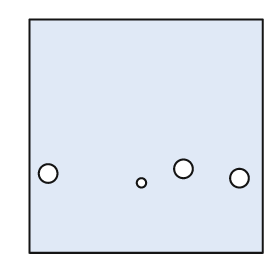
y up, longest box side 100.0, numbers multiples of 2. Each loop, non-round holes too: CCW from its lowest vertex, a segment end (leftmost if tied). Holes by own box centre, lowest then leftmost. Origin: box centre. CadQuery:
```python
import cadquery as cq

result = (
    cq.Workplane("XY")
    .moveTo(-50.0, -50.0)
    .lineTo(50.0, -50.0)
    .lineTo(50.0, 50.0)
    .lineTo(-50.0, 50.0)
    .close()
    .moveTo(-2.0, -20.0)
    .circle(2.0)
    .moveTo(40.0, -18.0)
    .circle(4.0)
    .moveTo(-42.0, -16.0)
    .circle(4.0)
    .moveTo(16.0, -14.0)
    .circle(4.0)
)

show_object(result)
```